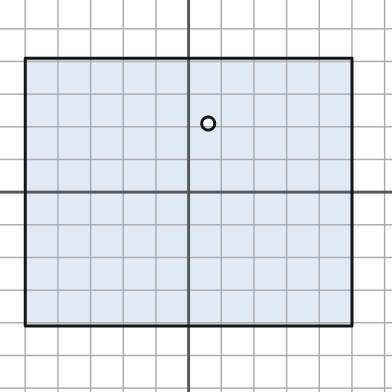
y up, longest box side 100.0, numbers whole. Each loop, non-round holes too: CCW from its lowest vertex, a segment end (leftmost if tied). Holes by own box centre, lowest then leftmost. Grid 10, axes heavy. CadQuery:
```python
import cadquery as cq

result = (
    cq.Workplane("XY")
    .moveTo(-50.0, -41.0)
    .lineTo(50.0, -41.0)
    .lineTo(50.0, 41.0)
    .lineTo(-50.0, 41.0)
    .close()
    .moveTo(6.0, 21.0)
    .circle(2.0)
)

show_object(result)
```